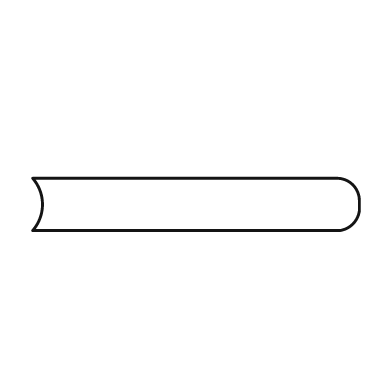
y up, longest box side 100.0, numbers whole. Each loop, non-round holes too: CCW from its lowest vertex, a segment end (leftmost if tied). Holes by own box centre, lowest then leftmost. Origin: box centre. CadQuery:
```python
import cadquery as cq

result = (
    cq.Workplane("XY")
    .moveTo(-50.0, -8.0)
    .lineTo(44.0, -8.0)
    .threePointArc((48.0, -6.0), (50.0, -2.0))
    .lineTo(50.0, 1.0)
    .threePointArc((48.0, 6.0), (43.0, 8.0))
    .lineTo(-50.0, 8.0)
    .threePointArc((-47.0, 0.0), (-50.0, -8.0))
    .close()
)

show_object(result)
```